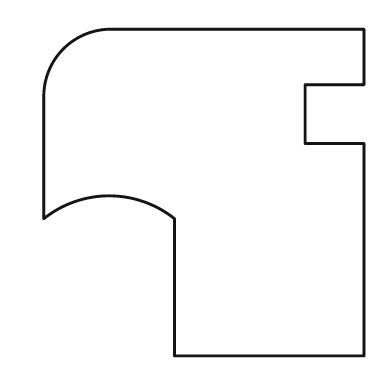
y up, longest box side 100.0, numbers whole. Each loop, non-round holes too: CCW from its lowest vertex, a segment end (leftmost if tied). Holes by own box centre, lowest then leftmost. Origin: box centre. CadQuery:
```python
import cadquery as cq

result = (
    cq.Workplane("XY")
    .moveTo(-9.0, -50.0)
    .lineTo(49.0, -50.0)
    .lineTo(49.0, 15.0)
    .lineTo(31.0, 15.0)
    .lineTo(31.0, 33.0)
    .lineTo(49.0, 33.0)
    .lineTo(49.0, 50.0)
    .lineTo(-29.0, 50.0)
    .threePointArc((-43.0, 44.0), (-49.0, 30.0))
    .lineTo(-49.0, -8.0)
    .threePointArc((-29.0, -1.0), (-9.0, -8.0))
    .close()
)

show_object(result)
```